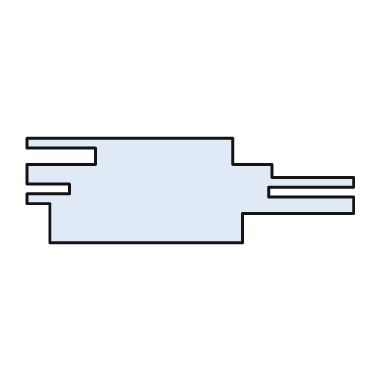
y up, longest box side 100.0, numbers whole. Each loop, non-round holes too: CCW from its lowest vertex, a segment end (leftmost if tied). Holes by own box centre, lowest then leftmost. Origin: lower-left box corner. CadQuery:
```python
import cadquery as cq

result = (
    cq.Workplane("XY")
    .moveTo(7.0, 0.0)
    .lineTo(66.0, 0.0)
    .lineTo(66.0, 9.0)
    .lineTo(100.0, 9.0)
    .lineTo(100.0, 14.0)
    .lineTo(74.0, 14.0)
    .lineTo(74.0, 17.0)
    .lineTo(100.0, 17.0)
    .lineTo(100.0, 20.0)
    .lineTo(75.0, 20.0)
    .lineTo(75.0, 24.0)
    .lineTo(63.0, 24.0)
    .lineTo(63.0, 32.0)
    .lineTo(0.0, 32.0)
    .lineTo(0.0, 29.0)
    .lineTo(21.0, 29.0)
    .lineTo(21.0, 24.0)
    .lineTo(0.0, 24.0)
    .lineTo(0.0, 18.0)
    .lineTo(13.0, 18.0)
    .lineTo(13.0, 15.0)
    .lineTo(0.0, 15.0)
    .lineTo(0.0, 12.0)
    .lineTo(7.0, 12.0)
    .close()
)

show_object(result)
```